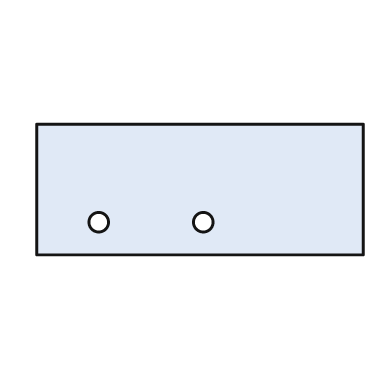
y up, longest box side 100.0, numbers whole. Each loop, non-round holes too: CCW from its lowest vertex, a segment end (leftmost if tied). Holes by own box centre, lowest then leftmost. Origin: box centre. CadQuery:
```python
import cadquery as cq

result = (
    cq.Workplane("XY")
    .moveTo(-50.0, -20.0)
    .lineTo(50.0, -20.0)
    .lineTo(50.0, 20.0)
    .lineTo(-50.0, 20.0)
    .close()
    .moveTo(-31.0, -10.0)
    .circle(3.0)
    .moveTo(1.0, -10.0)
    .circle(3.0)
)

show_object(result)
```